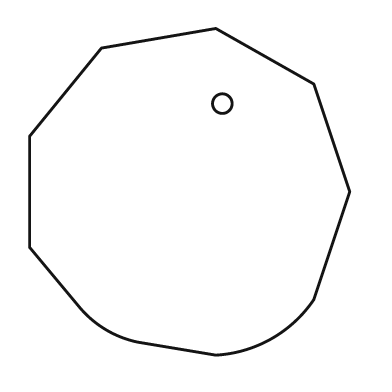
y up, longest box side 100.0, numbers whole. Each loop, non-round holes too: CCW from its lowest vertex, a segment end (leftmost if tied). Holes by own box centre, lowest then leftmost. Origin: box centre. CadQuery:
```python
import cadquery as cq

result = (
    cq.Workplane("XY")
    .moveTo(8.0, -50.0)
    .threePointArc((25.0, -45.0), (38.0, -33.0))
    .lineTo(49.0, 0.0)
    .lineTo(38.0, 33.0)
    .lineTo(8.0, 50.0)
    .lineTo(-27.0, 44.0)
    .lineTo(-49.0, 17.0)
    .lineTo(-49.0, -17.0)
    .lineTo(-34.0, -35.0)
    .threePointArc((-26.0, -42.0), (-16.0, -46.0))
    .close()
    .moveTo(10.0, 27.0)
    .circle(3.0)
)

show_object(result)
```